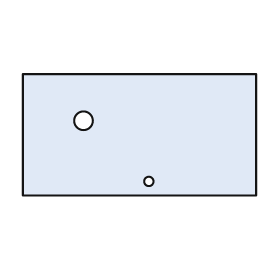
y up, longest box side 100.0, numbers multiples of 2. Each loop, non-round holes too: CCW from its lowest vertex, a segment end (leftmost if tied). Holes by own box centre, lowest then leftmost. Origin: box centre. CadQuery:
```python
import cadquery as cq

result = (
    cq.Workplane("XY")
    .moveTo(-50.0, -26.0)
    .lineTo(50.0, -26.0)
    .lineTo(50.0, 26.0)
    .lineTo(-50.0, 26.0)
    .close()
    .moveTo(4.0, -20.0)
    .circle(2.0)
    .moveTo(-24.0, 6.0)
    .circle(4.0)
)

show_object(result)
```